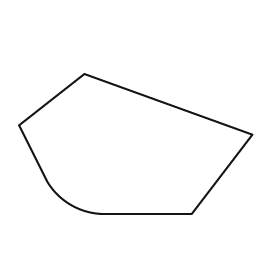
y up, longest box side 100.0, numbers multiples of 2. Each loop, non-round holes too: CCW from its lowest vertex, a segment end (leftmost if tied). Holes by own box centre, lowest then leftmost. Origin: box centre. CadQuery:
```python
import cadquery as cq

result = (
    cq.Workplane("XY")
    .moveTo(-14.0, -30.0)
    .lineTo(24.0, -30.0)
    .lineTo(50.0, 4.0)
    .lineTo(-22.0, 30.0)
    .lineTo(-50.0, 8.0)
    .lineTo(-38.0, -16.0)
    .threePointArc((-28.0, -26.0), (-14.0, -30.0))
    .close()
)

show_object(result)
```